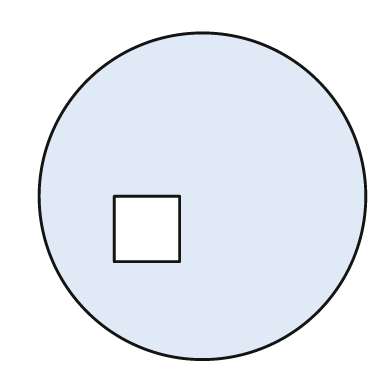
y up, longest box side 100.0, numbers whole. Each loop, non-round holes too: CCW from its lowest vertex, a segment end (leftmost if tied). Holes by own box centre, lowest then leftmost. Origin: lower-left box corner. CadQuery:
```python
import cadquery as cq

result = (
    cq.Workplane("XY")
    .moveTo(50.0, 50.0)
    .circle(50.0)
    .moveTo(23.0, 30.0)
    .lineTo(43.0, 30.0)
    .lineTo(43.0, 50.0)
    .lineTo(23.0, 50.0)
    .close()
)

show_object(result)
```